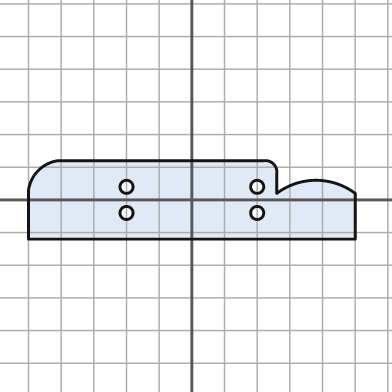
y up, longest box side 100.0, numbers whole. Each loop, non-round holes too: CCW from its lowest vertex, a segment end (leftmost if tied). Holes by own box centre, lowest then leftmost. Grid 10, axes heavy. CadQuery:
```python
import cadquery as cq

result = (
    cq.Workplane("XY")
    .moveTo(-50.0, -12.0)
    .lineTo(50.0, -12.0)
    .lineTo(50.0, 2.0)
    .threePointArc((38.0, 6.0), (26.0, 2.0))
    .lineTo(26.0, 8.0)
    .threePointArc((25.0, 11.0), (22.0, 12.0))
    .lineTo(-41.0, 12.0)
    .threePointArc((-47.0, 9.0), (-50.0, 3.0))
    .close()
    .moveTo(-20.0, -4.0)
    .circle(2.0)
    .moveTo(20.0, -4.0)
    .circle(2.0)
    .moveTo(-20.0, 4.0)
    .circle(2.0)
    .moveTo(20.0, 4.0)
    .circle(2.0)
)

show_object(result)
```